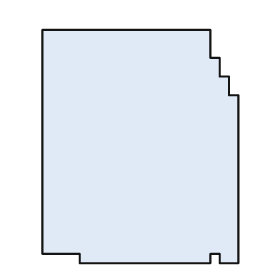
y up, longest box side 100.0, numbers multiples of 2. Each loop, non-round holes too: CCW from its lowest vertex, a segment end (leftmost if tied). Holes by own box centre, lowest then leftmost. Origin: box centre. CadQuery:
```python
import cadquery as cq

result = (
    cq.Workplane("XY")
    .moveTo(-26.0, -50.0)
    .lineTo(30.0, -50.0)
    .lineTo(30.0, -46.0)
    .lineTo(34.0, -46.0)
    .lineTo(34.0, -50.0)
    .lineTo(42.0, -50.0)
    .lineTo(42.0, 22.0)
    .lineTo(38.0, 22.0)
    .lineTo(38.0, 30.0)
    .lineTo(34.0, 30.0)
    .lineTo(34.0, 38.0)
    .lineTo(30.0, 38.0)
    .lineTo(30.0, 50.0)
    .lineTo(-42.0, 50.0)
    .lineTo(-42.0, -46.0)
    .lineTo(-26.0, -46.0)
    .close()
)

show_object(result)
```